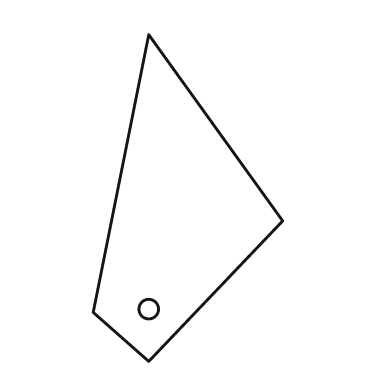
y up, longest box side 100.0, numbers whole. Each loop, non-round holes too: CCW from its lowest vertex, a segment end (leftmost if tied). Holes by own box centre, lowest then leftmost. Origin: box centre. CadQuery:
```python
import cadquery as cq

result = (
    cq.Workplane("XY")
    .moveTo(-12.0, -50.0)
    .lineTo(29.0, -7.0)
    .lineTo(-12.0, 50.0)
    .lineTo(-29.0, -35.0)
    .close()
    .moveTo(-12.0, -34.0)
    .circle(3.0)
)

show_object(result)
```